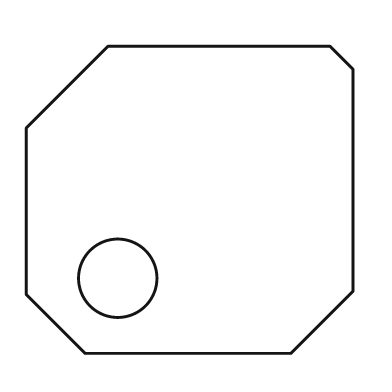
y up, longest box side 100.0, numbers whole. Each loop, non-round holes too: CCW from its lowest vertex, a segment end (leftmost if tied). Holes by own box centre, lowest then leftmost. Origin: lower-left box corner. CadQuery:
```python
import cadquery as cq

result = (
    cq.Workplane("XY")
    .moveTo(18.0, 0.0)
    .lineTo(81.0, 0.0)
    .lineTo(100.0, 19.0)
    .lineTo(100.0, 87.0)
    .lineTo(93.0, 94.0)
    .lineTo(25.0, 94.0)
    .lineTo(0.0, 69.0)
    .lineTo(0.0, 18.0)
    .close()
    .moveTo(28.0, 23.0)
    .circle(12.0)
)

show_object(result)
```